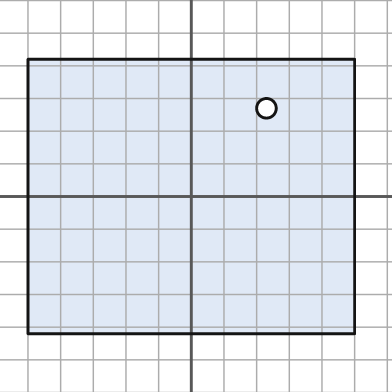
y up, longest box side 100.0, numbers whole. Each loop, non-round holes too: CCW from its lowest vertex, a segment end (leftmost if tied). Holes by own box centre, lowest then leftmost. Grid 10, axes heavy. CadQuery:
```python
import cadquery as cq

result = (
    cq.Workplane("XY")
    .moveTo(-50.0, -42.0)
    .lineTo(50.0, -42.0)
    .lineTo(50.0, 42.0)
    .lineTo(-50.0, 42.0)
    .close()
    .moveTo(23.0, 27.0)
    .circle(3.0)
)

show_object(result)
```